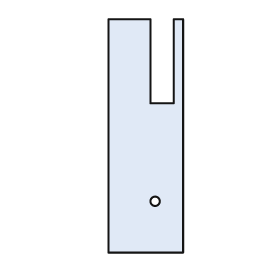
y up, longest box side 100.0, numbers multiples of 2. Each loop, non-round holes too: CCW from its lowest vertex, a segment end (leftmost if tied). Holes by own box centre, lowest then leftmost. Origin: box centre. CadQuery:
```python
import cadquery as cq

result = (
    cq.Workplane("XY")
    .moveTo(-16.0, -50.0)
    .lineTo(16.0, -50.0)
    .lineTo(16.0, 50.0)
    .lineTo(12.0, 50.0)
    .lineTo(12.0, 14.0)
    .lineTo(2.0, 14.0)
    .lineTo(2.0, 50.0)
    .lineTo(-16.0, 50.0)
    .close()
    .moveTo(4.0, -28.0)
    .circle(2.0)
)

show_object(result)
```